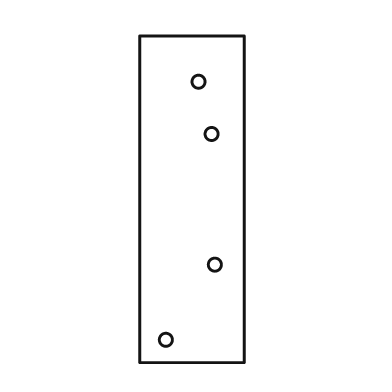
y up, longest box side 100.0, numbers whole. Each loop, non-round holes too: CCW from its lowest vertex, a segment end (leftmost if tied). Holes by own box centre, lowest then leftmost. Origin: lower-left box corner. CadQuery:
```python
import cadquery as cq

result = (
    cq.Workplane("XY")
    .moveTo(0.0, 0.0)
    .lineTo(32.0, 0.0)
    .lineTo(32.0, 100.0)
    .lineTo(0.0, 100.0)
    .close()
    .moveTo(8.0, 7.0)
    .circle(2.0)
    .moveTo(23.0, 30.0)
    .circle(2.0)
    .moveTo(22.0, 70.0)
    .circle(2.0)
    .moveTo(18.0, 86.0)
    .circle(2.0)
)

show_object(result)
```